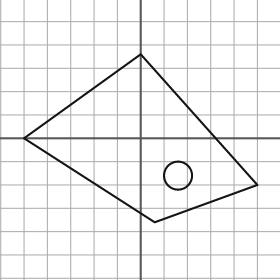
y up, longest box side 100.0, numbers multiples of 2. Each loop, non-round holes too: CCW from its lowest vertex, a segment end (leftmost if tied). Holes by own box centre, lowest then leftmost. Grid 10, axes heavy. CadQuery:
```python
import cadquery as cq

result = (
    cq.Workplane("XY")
    .moveTo(6.0, -36.0)
    .lineTo(50.0, -20.0)
    .lineTo(0.0, 36.0)
    .lineTo(-50.0, 0.0)
    .close()
    .moveTo(16.0, -16.0)
    .circle(6.0)
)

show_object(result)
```